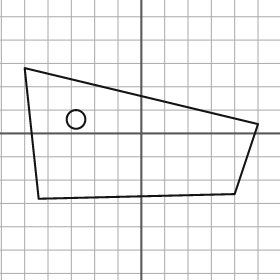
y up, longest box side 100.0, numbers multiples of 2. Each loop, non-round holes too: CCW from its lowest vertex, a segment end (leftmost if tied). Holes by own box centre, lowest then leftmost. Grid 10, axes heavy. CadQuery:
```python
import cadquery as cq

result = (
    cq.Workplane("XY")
    .moveTo(-44.0, -28.0)
    .lineTo(40.0, -26.0)
    .lineTo(50.0, 4.0)
    .lineTo(-50.0, 28.0)
    .close()
    .moveTo(-28.0, 6.0)
    .circle(4.0)
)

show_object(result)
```